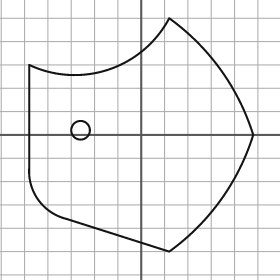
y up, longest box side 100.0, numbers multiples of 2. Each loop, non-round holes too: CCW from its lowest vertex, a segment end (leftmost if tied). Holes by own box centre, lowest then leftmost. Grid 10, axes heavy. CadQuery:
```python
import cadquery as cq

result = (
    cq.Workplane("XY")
    .moveTo(12.0, -50.0)
    .threePointArc((34.0, -28.0), (48.0, 0.0))
    .threePointArc((34.0, 28.0), (12.0, 50.0))
    .threePointArc((-14.0, 28.0), (-48.0, 30.0))
    .lineTo(-48.0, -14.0)
    .threePointArc((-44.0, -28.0), (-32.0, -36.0))
    .close()
    .moveTo(-26.0, 2.0)
    .circle(4.0)
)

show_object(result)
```